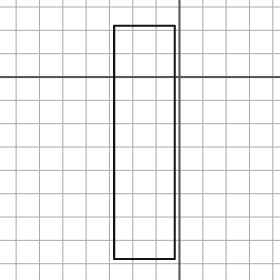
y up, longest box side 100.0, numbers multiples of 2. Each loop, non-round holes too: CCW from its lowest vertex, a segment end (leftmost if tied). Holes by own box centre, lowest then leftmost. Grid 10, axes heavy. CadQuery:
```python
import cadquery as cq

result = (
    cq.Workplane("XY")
    .moveTo(-28.0, -78.0)
    .lineTo(-2.0, -78.0)
    .lineTo(-2.0, 22.0)
    .lineTo(-28.0, 22.0)
    .close()
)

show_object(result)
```